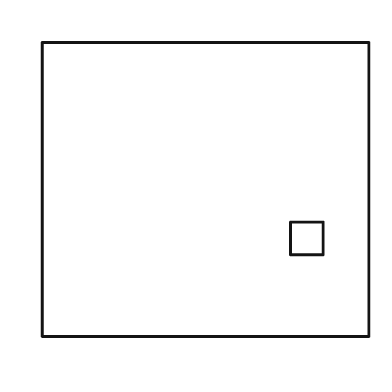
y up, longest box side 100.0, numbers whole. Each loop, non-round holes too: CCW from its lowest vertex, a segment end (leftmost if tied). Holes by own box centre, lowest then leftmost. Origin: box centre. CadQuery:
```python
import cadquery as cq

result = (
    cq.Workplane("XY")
    .moveTo(-50.0, -45.0)
    .lineTo(50.0, -45.0)
    .lineTo(50.0, 45.0)
    .lineTo(-50.0, 45.0)
    .close()
    .moveTo(26.0, -20.0)
    .lineTo(36.0, -20.0)
    .lineTo(36.0, -10.0)
    .lineTo(26.0, -10.0)
    .close()
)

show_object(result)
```